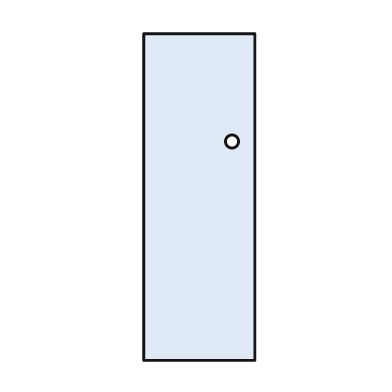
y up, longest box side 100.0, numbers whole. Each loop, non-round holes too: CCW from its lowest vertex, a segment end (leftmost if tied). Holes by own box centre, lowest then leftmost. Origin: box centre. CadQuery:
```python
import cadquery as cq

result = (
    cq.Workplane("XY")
    .moveTo(-17.0, -50.0)
    .lineTo(17.0, -50.0)
    .lineTo(17.0, 50.0)
    .lineTo(-17.0, 50.0)
    .close()
    .moveTo(10.0, 17.0)
    .circle(2.0)
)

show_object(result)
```